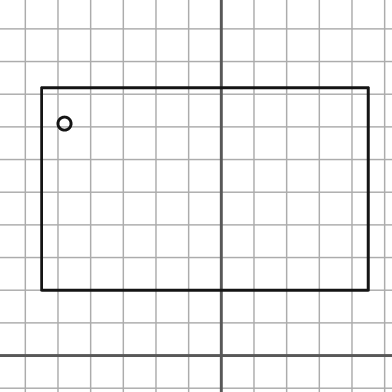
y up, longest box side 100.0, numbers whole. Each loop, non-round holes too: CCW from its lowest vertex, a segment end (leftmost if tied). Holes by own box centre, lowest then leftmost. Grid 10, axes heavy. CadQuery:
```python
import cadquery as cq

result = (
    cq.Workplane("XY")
    .moveTo(-55.0, 20.0)
    .lineTo(45.0, 20.0)
    .lineTo(45.0, 82.0)
    .lineTo(-55.0, 82.0)
    .close()
    .moveTo(-48.0, 71.0)
    .circle(2.0)
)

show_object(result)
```